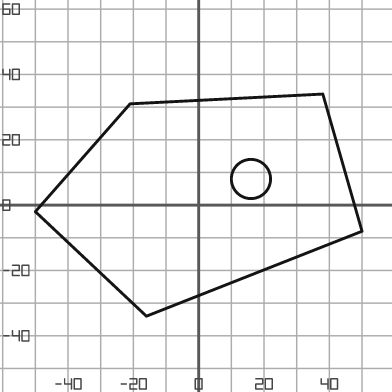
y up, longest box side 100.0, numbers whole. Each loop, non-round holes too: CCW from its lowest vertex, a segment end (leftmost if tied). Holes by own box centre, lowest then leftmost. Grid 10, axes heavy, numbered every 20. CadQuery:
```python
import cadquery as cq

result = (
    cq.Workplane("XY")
    .moveTo(-16.0, -34.0)
    .lineTo(50.0, -8.0)
    .lineTo(38.0, 34.0)
    .lineTo(-21.0, 31.0)
    .lineTo(-50.0, -2.0)
    .close()
    .moveTo(16.0, 8.0)
    .circle(6.0)
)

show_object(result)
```